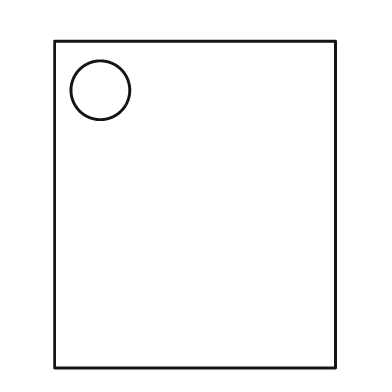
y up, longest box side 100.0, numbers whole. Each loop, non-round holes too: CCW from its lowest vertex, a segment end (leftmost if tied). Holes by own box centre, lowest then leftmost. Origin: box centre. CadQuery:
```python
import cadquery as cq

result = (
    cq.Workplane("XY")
    .moveTo(-43.0, -50.0)
    .lineTo(43.0, -50.0)
    .lineTo(43.0, 50.0)
    .lineTo(-43.0, 50.0)
    .close()
    .moveTo(-29.0, 35.0)
    .circle(9.0)
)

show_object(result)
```